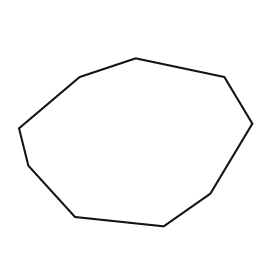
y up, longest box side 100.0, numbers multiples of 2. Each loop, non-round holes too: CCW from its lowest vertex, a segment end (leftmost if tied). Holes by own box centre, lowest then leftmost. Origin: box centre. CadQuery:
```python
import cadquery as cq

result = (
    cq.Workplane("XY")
    .moveTo(12.0, -36.0)
    .lineTo(32.0, -22.0)
    .lineTo(50.0, 8.0)
    .lineTo(38.0, 28.0)
    .lineTo(0.0, 36.0)
    .lineTo(-24.0, 28.0)
    .lineTo(-50.0, 6.0)
    .lineTo(-46.0, -10.0)
    .lineTo(-26.0, -32.0)
    .close()
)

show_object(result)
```